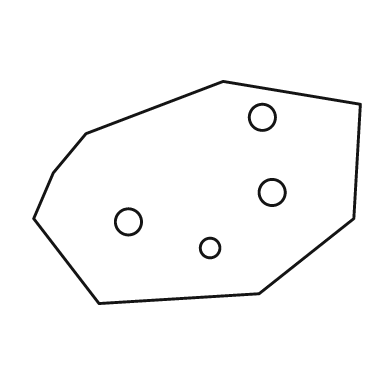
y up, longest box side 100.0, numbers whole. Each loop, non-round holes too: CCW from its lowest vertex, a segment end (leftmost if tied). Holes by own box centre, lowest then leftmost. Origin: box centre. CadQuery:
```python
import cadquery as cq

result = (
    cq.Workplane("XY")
    .moveTo(-30.0, -34.0)
    .lineTo(19.0, -31.0)
    .lineTo(48.0, -8.0)
    .lineTo(50.0, 27.0)
    .lineTo(8.0, 34.0)
    .lineTo(-34.0, 18.0)
    .lineTo(-44.0, 6.0)
    .lineTo(-50.0, -8.0)
    .close()
    .moveTo(4.0, -17.0)
    .circle(3.0)
    .moveTo(-21.0, -9.0)
    .circle(4.0)
    .moveTo(23.0, 0.0)
    .circle(4.0)
    .moveTo(20.0, 23.0)
    .circle(4.0)
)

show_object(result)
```